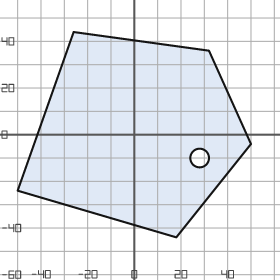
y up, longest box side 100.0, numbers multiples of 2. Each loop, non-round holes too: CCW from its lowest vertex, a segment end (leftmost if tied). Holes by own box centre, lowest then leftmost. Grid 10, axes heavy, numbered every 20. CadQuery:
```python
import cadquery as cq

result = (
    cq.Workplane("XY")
    .moveTo(18.0, -44.0)
    .lineTo(50.0, -4.0)
    .lineTo(32.0, 36.0)
    .lineTo(-26.0, 44.0)
    .lineTo(-50.0, -24.0)
    .close()
    .moveTo(28.0, -10.0)
    .circle(4.0)
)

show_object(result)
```